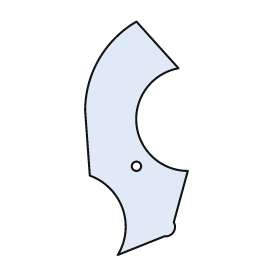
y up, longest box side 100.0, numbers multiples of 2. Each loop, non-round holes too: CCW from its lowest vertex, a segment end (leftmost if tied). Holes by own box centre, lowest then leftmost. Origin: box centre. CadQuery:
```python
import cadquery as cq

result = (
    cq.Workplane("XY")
    .moveTo(-8.0, -50.0)
    .lineTo(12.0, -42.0)
    .threePointArc((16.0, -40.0), (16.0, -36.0))
    .lineTo(22.0, -14.0)
    .threePointArc((0.0, 6.0), (18.0, 30.0))
    .lineTo(0.0, 50.0)
    .threePointArc((-16.0, 34.0), (-22.0, 12.0))
    .lineTo(-20.0, -16.0)
    .threePointArc((-6.0, -30.0), (-8.0, -50.0))
    .close()
    .moveTo(0.0, -12.0)
    .circle(2.0)
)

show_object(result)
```